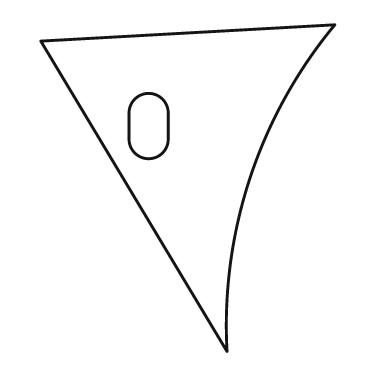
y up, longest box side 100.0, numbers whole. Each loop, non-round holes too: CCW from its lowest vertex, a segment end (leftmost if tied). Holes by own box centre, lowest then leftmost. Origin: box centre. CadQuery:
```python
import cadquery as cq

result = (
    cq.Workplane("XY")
    .moveTo(12.0, -50.0)
    .threePointArc((19.0, 3.0), (45.0, 50.0))
    .lineTo(-45.0, 45.0)
    .close()
    .moveTo(-18.0, 15.0)
    .threePointArc((-12.0, 9.0), (-6.0, 15.0))
    .lineTo(-6.0, 23.0)
    .threePointArc((-12.0, 29.0), (-18.0, 23.0))
    .close()
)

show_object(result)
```